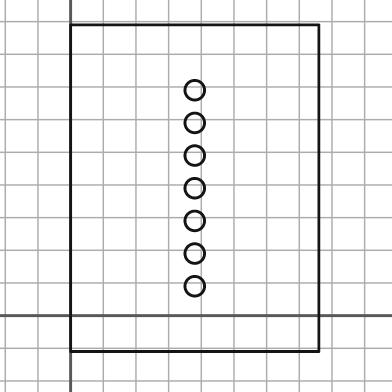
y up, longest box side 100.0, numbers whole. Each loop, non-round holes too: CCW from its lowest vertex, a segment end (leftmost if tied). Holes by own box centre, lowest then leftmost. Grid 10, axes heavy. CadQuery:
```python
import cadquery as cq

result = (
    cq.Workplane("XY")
    .moveTo(0.0, -11.0)
    .lineTo(76.0, -11.0)
    .lineTo(76.0, 89.0)
    .lineTo(0.0, 89.0)
    .close()
    .moveTo(38.0, 9.0)
    .circle(3.0)
    .moveTo(38.0, 19.0)
    .circle(3.0)
    .moveTo(38.0, 29.0)
    .circle(3.0)
    .moveTo(38.0, 39.0)
    .circle(3.0)
    .moveTo(38.0, 49.0)
    .circle(3.0)
    .moveTo(38.0, 59.0)
    .circle(3.0)
    .moveTo(38.0, 69.0)
    .circle(3.0)
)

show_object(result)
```